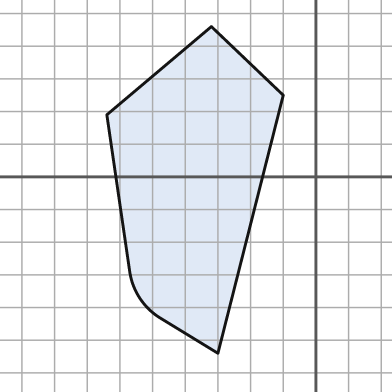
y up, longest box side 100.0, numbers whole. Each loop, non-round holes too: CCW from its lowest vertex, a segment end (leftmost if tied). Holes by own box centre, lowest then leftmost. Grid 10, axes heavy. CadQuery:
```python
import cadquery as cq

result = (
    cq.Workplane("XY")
    .moveTo(-30.0, -54.0)
    .lineTo(-10.0, 25.0)
    .lineTo(-32.0, 46.0)
    .lineTo(-64.0, 19.0)
    .lineTo(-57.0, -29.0)
    .threePointArc((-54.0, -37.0), (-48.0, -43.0))
    .close()
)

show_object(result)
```